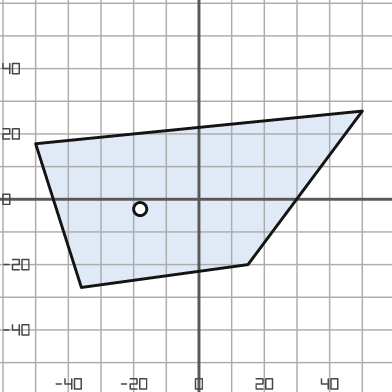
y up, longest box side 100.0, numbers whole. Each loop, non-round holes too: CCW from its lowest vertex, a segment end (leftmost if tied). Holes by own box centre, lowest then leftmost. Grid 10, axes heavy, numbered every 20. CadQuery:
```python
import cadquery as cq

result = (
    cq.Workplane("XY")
    .moveTo(-36.0, -27.0)
    .lineTo(15.0, -20.0)
    .lineTo(50.0, 27.0)
    .lineTo(-50.0, 17.0)
    .close()
    .moveTo(-18.0, -3.0)
    .circle(2.0)
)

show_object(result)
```